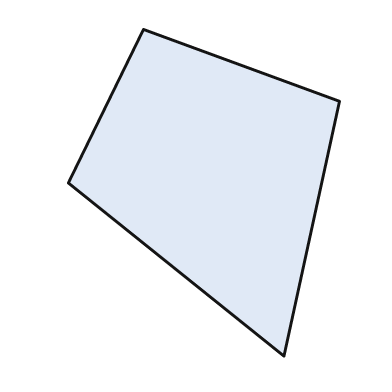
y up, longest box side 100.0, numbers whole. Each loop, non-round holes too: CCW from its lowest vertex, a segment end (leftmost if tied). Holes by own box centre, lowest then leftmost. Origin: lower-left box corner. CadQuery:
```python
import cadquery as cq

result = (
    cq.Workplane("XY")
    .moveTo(66.0, 0.0)
    .lineTo(83.0, 78.0)
    .lineTo(23.0, 100.0)
    .lineTo(0.0, 53.0)
    .close()
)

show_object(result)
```